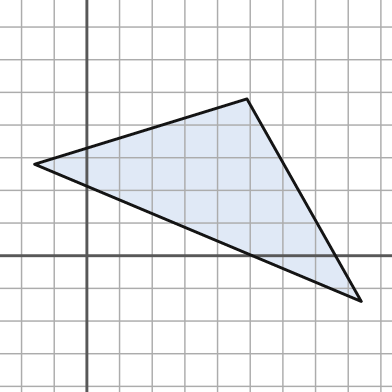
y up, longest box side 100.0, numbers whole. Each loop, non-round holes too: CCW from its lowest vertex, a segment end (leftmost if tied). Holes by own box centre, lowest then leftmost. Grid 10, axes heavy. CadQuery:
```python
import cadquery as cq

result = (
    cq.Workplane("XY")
    .moveTo(84.0, -14.0)
    .lineTo(49.0, 48.0)
    .lineTo(-16.0, 28.0)
    .close()
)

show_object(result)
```